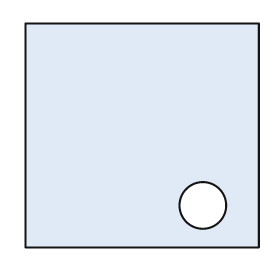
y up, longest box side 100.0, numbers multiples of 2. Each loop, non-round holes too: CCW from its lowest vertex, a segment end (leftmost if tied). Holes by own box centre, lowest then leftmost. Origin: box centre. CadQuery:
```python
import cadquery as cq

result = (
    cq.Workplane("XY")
    .moveTo(-50.0, -48.0)
    .lineTo(50.0, -48.0)
    .lineTo(50.0, 48.0)
    .lineTo(-50.0, 48.0)
    .close()
    .moveTo(26.0, -30.0)
    .circle(10.0)
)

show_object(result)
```